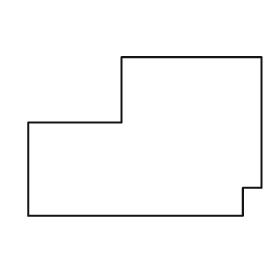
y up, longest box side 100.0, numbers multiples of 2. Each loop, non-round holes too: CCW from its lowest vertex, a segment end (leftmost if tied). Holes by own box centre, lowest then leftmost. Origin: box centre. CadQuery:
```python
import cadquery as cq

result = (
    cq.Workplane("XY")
    .moveTo(-50.0, -34.0)
    .lineTo(42.0, -34.0)
    .lineTo(42.0, -22.0)
    .lineTo(50.0, -22.0)
    .lineTo(50.0, 34.0)
    .lineTo(-10.0, 34.0)
    .lineTo(-10.0, 6.0)
    .lineTo(-50.0, 6.0)
    .close()
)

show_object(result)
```